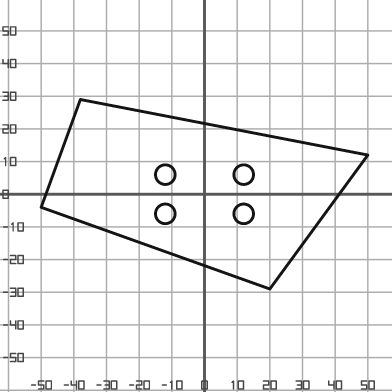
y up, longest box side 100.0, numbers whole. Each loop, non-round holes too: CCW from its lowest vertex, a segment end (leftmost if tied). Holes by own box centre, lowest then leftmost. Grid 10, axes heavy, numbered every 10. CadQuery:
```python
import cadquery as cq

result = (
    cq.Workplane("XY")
    .moveTo(20.0, -29.0)
    .lineTo(50.0, 12.0)
    .lineTo(-38.0, 29.0)
    .lineTo(-50.0, -4.0)
    .close()
    .moveTo(-12.0, -6.0)
    .circle(3.0)
    .moveTo(12.0, -6.0)
    .circle(3.0)
    .moveTo(-12.0, 6.0)
    .circle(3.0)
    .moveTo(12.0, 6.0)
    .circle(3.0)
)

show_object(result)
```